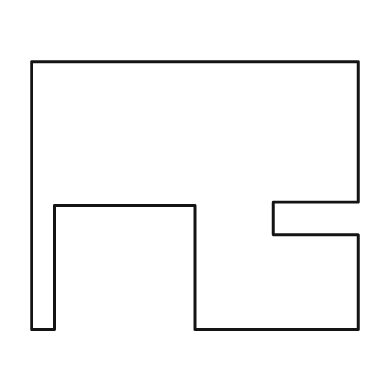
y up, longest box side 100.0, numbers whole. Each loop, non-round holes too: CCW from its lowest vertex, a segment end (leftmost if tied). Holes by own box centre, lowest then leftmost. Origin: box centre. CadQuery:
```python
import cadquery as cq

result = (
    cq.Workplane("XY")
    .moveTo(-50.0, -41.0)
    .lineTo(-43.0, -41.0)
    .lineTo(-43.0, -3.0)
    .lineTo(0.0, -3.0)
    .lineTo(0.0, -41.0)
    .lineTo(50.0, -41.0)
    .lineTo(50.0, -12.0)
    .lineTo(24.0, -12.0)
    .lineTo(24.0, -2.0)
    .lineTo(50.0, -2.0)
    .lineTo(50.0, 41.0)
    .lineTo(-50.0, 41.0)
    .close()
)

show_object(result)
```